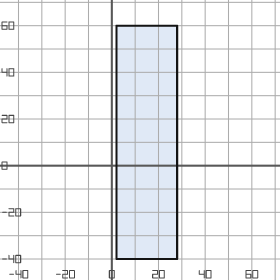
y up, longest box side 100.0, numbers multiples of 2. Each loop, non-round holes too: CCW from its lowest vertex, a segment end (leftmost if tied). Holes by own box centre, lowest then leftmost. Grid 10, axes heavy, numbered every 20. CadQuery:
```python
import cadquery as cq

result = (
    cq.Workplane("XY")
    .moveTo(2.0, -40.0)
    .lineTo(28.0, -40.0)
    .lineTo(28.0, 60.0)
    .lineTo(2.0, 60.0)
    .close()
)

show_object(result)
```